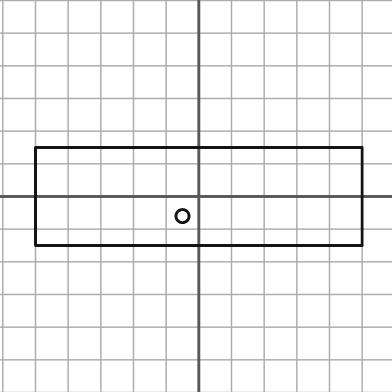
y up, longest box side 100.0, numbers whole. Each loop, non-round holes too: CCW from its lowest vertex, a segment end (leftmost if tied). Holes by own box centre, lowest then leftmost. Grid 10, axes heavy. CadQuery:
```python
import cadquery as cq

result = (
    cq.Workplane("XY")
    .moveTo(-50.0, -15.0)
    .lineTo(50.0, -15.0)
    .lineTo(50.0, 15.0)
    .lineTo(-50.0, 15.0)
    .close()
    .moveTo(-5.0, -6.0)
    .circle(2.0)
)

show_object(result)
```